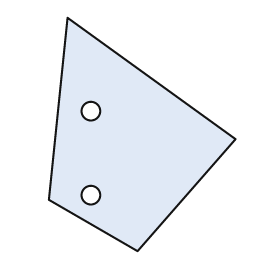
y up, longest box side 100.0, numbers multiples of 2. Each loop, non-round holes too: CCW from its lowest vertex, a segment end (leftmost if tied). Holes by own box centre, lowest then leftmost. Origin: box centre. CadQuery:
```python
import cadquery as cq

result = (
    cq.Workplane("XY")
    .moveTo(-2.0, -50.0)
    .lineTo(40.0, -2.0)
    .lineTo(-32.0, 50.0)
    .lineTo(-40.0, -28.0)
    .close()
    .moveTo(-22.0, -26.0)
    .circle(4.0)
    .moveTo(-22.0, 10.0)
    .circle(4.0)
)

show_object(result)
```